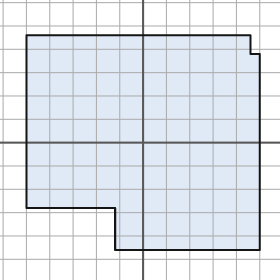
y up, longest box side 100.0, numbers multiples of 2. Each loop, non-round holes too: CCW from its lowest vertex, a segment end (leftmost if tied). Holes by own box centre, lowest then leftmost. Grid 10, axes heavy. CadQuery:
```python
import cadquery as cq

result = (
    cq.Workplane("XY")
    .moveTo(-12.0, -46.0)
    .lineTo(50.0, -46.0)
    .lineTo(50.0, 38.0)
    .lineTo(46.0, 38.0)
    .lineTo(46.0, 46.0)
    .lineTo(-50.0, 46.0)
    .lineTo(-50.0, -28.0)
    .lineTo(-12.0, -28.0)
    .close()
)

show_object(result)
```